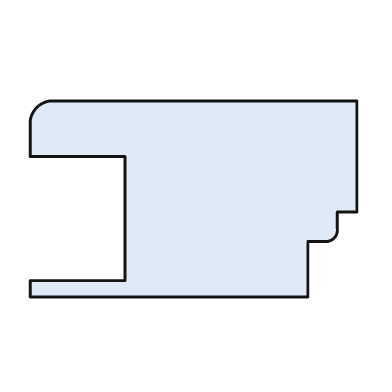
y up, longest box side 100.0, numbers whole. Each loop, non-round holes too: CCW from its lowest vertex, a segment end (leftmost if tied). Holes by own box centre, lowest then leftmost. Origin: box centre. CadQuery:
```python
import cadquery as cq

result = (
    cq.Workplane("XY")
    .moveTo(-50.0, -30.0)
    .lineTo(35.0, -30.0)
    .lineTo(35.0, -13.0)
    .lineTo(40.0, -13.0)
    .threePointArc((43.0, -12.0), (44.0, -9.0))
    .lineTo(44.0, -4.0)
    .lineTo(50.0, -4.0)
    .lineTo(50.0, 30.0)
    .lineTo(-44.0, 30.0)
    .threePointArc((-48.0, 28.0), (-50.0, 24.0))
    .lineTo(-50.0, 13.0)
    .lineTo(-21.0, 13.0)
    .lineTo(-21.0, -25.0)
    .lineTo(-50.0, -25.0)
    .close()
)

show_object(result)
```